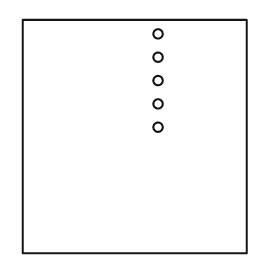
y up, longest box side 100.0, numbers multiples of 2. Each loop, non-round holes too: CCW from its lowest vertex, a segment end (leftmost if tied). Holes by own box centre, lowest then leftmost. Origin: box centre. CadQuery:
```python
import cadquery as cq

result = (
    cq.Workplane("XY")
    .moveTo(-48.0, -50.0)
    .lineTo(48.0, -50.0)
    .lineTo(48.0, 50.0)
    .lineTo(-48.0, 50.0)
    .close()
    .moveTo(10.0, 4.0)
    .circle(2.0)
    .moveTo(10.0, 14.0)
    .circle(2.0)
    .moveTo(10.0, 24.0)
    .circle(2.0)
    .moveTo(10.0, 34.0)
    .circle(2.0)
    .moveTo(10.0, 44.0)
    .circle(2.0)
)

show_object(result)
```